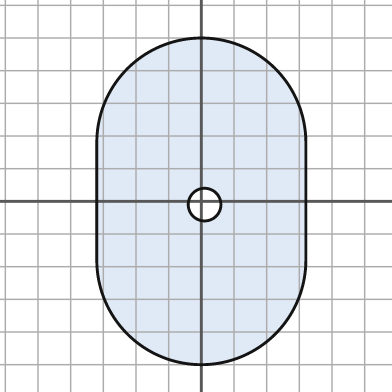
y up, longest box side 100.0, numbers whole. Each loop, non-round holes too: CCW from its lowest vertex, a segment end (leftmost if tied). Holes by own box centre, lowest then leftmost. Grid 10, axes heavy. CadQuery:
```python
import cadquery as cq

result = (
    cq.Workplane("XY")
    .moveTo(-32.0, -18.0)
    .threePointArc((0.0, -50.0), (32.0, -18.0))
    .lineTo(32.0, 18.0)
    .threePointArc((0.0, 50.0), (-32.0, 18.0))
    .close()
    .moveTo(1.0, -1.0)
    .circle(5.0)
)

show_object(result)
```